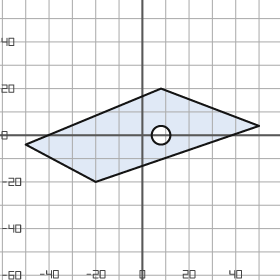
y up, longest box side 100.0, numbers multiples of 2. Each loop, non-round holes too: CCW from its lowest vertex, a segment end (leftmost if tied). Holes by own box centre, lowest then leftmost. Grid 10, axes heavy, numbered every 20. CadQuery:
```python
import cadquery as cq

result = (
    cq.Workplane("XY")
    .moveTo(-20.0, -20.0)
    .lineTo(50.0, 4.0)
    .lineTo(8.0, 20.0)
    .lineTo(-50.0, -4.0)
    .close()
    .moveTo(8.0, 0.0)
    .circle(4.0)
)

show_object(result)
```